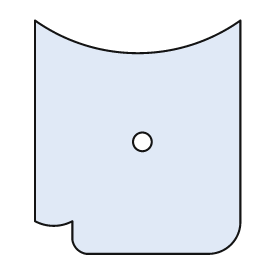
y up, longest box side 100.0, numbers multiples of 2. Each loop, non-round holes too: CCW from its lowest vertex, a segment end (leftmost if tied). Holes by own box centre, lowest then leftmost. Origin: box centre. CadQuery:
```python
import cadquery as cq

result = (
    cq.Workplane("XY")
    .moveTo(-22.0, -50.0)
    .lineTo(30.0, -50.0)
    .threePointArc((40.0, -46.0), (44.0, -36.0))
    .lineTo(44.0, 50.0)
    .threePointArc((0.0, 36.0), (-44.0, 50.0))
    .lineTo(-44.0, -36.0)
    .threePointArc((-36.0, -38.0), (-28.0, -36.0))
    .lineTo(-28.0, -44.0)
    .threePointArc((-26.0, -48.0), (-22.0, -50.0))
    .close()
    .moveTo(2.0, -2.0)
    .circle(4.0)
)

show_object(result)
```